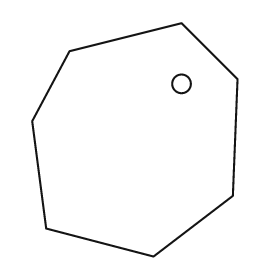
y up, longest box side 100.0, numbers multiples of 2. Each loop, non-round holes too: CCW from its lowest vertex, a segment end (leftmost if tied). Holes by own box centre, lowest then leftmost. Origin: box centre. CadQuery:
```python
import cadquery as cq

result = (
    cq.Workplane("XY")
    .moveTo(8.0, -50.0)
    .lineTo(42.0, -24.0)
    .lineTo(44.0, 26.0)
    .lineTo(20.0, 50.0)
    .lineTo(-28.0, 38.0)
    .lineTo(-44.0, 8.0)
    .lineTo(-38.0, -38.0)
    .close()
    .moveTo(20.0, 24.0)
    .circle(4.0)
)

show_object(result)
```